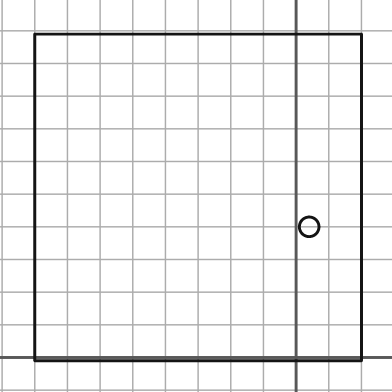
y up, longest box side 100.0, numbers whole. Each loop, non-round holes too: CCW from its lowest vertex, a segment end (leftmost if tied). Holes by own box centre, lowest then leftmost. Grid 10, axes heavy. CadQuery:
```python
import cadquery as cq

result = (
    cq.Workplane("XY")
    .moveTo(-80.0, -1.0)
    .lineTo(20.0, -1.0)
    .lineTo(20.0, 99.0)
    .lineTo(-80.0, 99.0)
    .close()
    .moveTo(4.0, 40.0)
    .circle(3.0)
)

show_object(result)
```